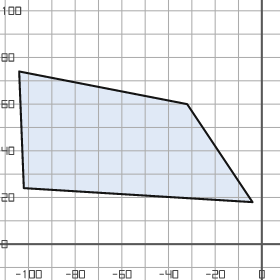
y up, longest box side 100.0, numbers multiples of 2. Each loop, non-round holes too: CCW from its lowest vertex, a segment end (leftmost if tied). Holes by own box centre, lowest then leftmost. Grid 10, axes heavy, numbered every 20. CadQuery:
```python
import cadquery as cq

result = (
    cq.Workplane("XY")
    .moveTo(-4.0, 18.0)
    .lineTo(-32.0, 60.0)
    .lineTo(-104.0, 74.0)
    .lineTo(-102.0, 24.0)
    .close()
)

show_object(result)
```